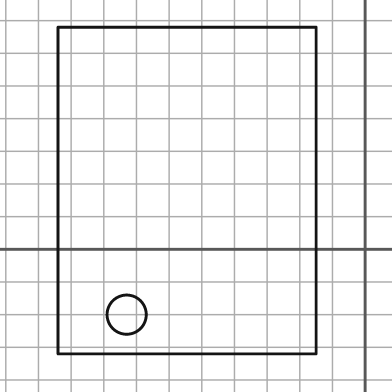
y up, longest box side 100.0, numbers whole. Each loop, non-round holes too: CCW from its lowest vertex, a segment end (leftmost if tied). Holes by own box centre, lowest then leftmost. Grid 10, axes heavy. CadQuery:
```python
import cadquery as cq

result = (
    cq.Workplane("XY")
    .moveTo(-94.0, -32.0)
    .lineTo(-15.0, -32.0)
    .lineTo(-15.0, 68.0)
    .lineTo(-94.0, 68.0)
    .close()
    .moveTo(-73.0, -20.0)
    .circle(6.0)
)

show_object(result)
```